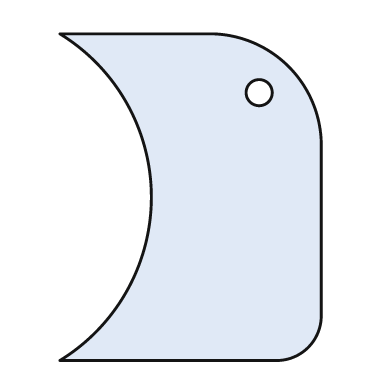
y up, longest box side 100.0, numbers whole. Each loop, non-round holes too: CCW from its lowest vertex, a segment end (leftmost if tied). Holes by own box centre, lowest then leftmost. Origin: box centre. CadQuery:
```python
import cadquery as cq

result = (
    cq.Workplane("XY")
    .moveTo(-40.0, -50.0)
    .lineTo(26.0, -50.0)
    .threePointArc((36.0, -46.0), (40.0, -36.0))
    .lineTo(40.0, 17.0)
    .threePointArc((30.0, 40.0), (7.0, 50.0))
    .lineTo(-40.0, 50.0)
    .threePointArc((-12.0, 0.0), (-40.0, -50.0))
    .close()
    .moveTo(21.0, 32.0)
    .circle(4.0)
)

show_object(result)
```